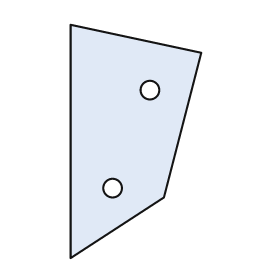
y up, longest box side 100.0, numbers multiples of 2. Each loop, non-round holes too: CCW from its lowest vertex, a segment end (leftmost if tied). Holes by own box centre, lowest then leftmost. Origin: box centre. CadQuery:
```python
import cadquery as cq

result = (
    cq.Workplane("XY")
    .moveTo(-28.0, -50.0)
    .lineTo(12.0, -24.0)
    .lineTo(28.0, 38.0)
    .lineTo(-28.0, 50.0)
    .close()
    .moveTo(-10.0, -20.0)
    .circle(4.0)
    .moveTo(6.0, 22.0)
    .circle(4.0)
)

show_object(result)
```